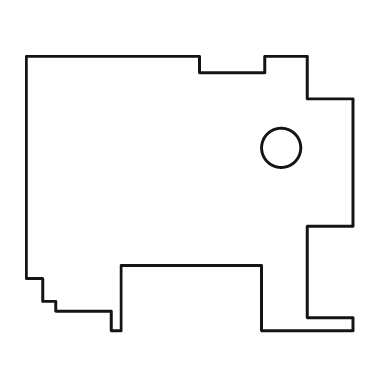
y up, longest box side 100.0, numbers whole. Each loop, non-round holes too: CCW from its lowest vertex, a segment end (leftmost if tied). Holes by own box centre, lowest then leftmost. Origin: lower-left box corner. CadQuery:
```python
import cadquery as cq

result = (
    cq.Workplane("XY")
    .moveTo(26.0, 0.0)
    .lineTo(29.0, 0.0)
    .lineTo(29.0, 20.0)
    .lineTo(72.0, 20.0)
    .lineTo(72.0, 0.0)
    .lineTo(100.0, 0.0)
    .lineTo(100.0, 4.0)
    .lineTo(86.0, 4.0)
    .lineTo(86.0, 32.0)
    .lineTo(100.0, 32.0)
    .lineTo(100.0, 71.0)
    .lineTo(86.0, 71.0)
    .lineTo(86.0, 84.0)
    .lineTo(73.0, 84.0)
    .lineTo(73.0, 79.0)
    .lineTo(53.0, 79.0)
    .lineTo(53.0, 84.0)
    .lineTo(0.0, 84.0)
    .lineTo(0.0, 16.0)
    .lineTo(5.0, 16.0)
    .lineTo(5.0, 9.0)
    .lineTo(9.0, 9.0)
    .lineTo(9.0, 6.0)
    .lineTo(26.0, 6.0)
    .close()
    .moveTo(78.0, 56.0)
    .circle(6.0)
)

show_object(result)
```